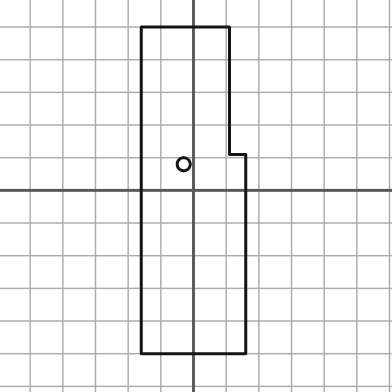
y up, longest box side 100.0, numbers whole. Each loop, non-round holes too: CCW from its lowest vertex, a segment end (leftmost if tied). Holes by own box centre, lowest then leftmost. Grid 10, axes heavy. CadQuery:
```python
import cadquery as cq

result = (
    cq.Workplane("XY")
    .moveTo(-16.0, -50.0)
    .lineTo(16.0, -50.0)
    .lineTo(16.0, 11.0)
    .lineTo(11.0, 11.0)
    .lineTo(11.0, 50.0)
    .lineTo(-16.0, 50.0)
    .close()
    .moveTo(-3.0, 8.0)
    .circle(2.0)
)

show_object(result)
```